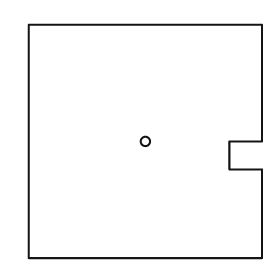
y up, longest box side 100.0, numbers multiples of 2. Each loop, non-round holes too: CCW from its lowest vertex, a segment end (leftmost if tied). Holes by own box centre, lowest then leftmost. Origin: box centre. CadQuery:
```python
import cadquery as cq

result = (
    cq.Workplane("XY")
    .moveTo(-50.0, -50.0)
    .lineTo(50.0, -50.0)
    .lineTo(50.0, -12.0)
    .lineTo(36.0, -12.0)
    .lineTo(36.0, 0.0)
    .lineTo(50.0, 0.0)
    .lineTo(50.0, 50.0)
    .lineTo(-50.0, 50.0)
    .close()
    .moveTo(0.0, 0.0)
    .circle(2.0)
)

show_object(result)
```